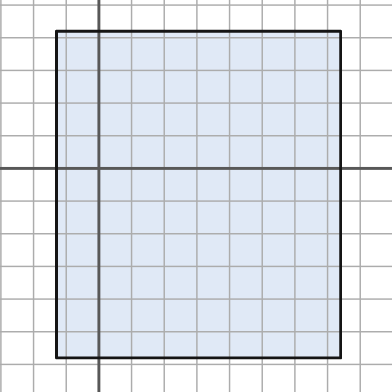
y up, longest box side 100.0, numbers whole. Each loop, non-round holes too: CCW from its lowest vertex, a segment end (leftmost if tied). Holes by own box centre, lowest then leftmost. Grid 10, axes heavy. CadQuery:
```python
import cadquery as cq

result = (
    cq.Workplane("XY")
    .moveTo(-13.0, -58.0)
    .lineTo(74.0, -58.0)
    .lineTo(74.0, 42.0)
    .lineTo(-13.0, 42.0)
    .close()
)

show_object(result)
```